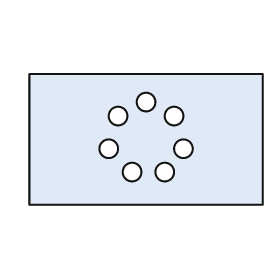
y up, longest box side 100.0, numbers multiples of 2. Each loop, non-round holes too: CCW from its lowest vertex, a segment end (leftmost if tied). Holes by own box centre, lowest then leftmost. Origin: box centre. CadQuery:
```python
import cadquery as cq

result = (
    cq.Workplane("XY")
    .moveTo(-50.0, -28.0)
    .lineTo(50.0, -28.0)
    .lineTo(50.0, 28.0)
    .lineTo(-50.0, 28.0)
    .close()
    .moveTo(-6.0, -14.0)
    .circle(4.0)
    .moveTo(8.0, -14.0)
    .circle(4.0)
    .moveTo(-16.0, -4.0)
    .circle(4.0)
    .moveTo(16.0, -4.0)
    .circle(4.0)
    .moveTo(-12.0, 10.0)
    .circle(4.0)
    .moveTo(12.0, 10.0)
    .circle(4.0)
    .moveTo(0.0, 16.0)
    .circle(4.0)
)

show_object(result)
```